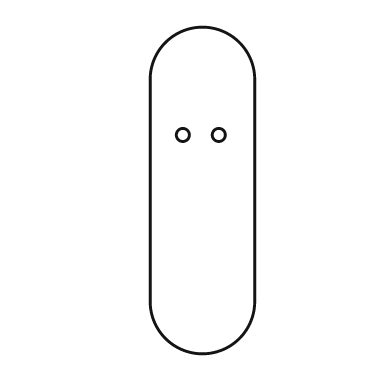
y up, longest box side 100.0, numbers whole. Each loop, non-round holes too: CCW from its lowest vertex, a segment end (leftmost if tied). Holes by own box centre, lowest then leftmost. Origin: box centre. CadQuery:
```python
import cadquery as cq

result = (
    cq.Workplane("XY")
    .moveTo(-16.0, -34.0)
    .threePointArc((0.0, -50.0), (16.0, -34.0))
    .lineTo(16.0, 34.0)
    .threePointArc((0.0, 50.0), (-16.0, 34.0))
    .close()
    .moveTo(-6.0, 17.0)
    .circle(2.0)
    .moveTo(5.0, 17.0)
    .circle(2.0)
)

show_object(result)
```